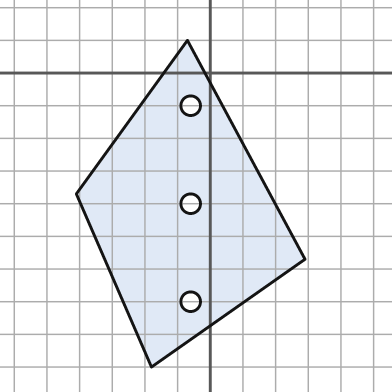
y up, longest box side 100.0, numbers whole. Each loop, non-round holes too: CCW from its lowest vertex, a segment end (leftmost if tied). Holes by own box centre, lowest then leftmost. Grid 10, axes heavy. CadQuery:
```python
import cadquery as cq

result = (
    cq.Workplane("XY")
    .moveTo(-18.0, -90.0)
    .lineTo(29.0, -57.0)
    .lineTo(-7.0, 10.0)
    .lineTo(-41.0, -37.0)
    .close()
    .moveTo(-6.0, -70.0)
    .circle(3.0)
    .moveTo(-6.0, -40.0)
    .circle(3.0)
    .moveTo(-6.0, -10.0)
    .circle(3.0)
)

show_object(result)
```